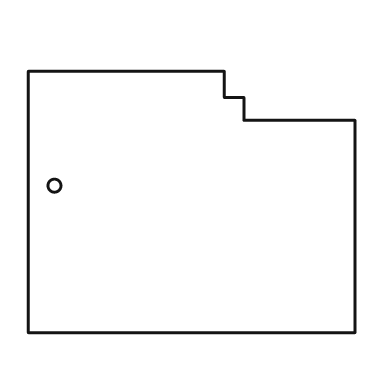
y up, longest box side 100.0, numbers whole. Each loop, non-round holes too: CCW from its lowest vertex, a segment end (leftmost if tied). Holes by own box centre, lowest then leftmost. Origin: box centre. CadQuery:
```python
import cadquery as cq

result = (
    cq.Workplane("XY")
    .moveTo(-50.0, -40.0)
    .lineTo(50.0, -40.0)
    .lineTo(50.0, 25.0)
    .lineTo(16.0, 25.0)
    .lineTo(16.0, 32.0)
    .lineTo(10.0, 32.0)
    .lineTo(10.0, 40.0)
    .lineTo(-50.0, 40.0)
    .close()
    .moveTo(-42.0, 5.0)
    .circle(2.0)
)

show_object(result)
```